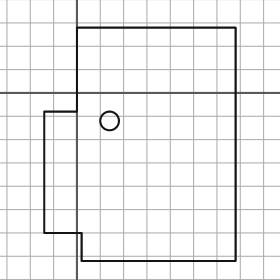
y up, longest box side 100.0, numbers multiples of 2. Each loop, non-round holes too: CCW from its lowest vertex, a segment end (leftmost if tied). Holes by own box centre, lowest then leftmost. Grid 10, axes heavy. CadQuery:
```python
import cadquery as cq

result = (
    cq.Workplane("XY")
    .moveTo(2.0, -72.0)
    .lineTo(68.0, -72.0)
    .lineTo(68.0, 28.0)
    .lineTo(0.0, 28.0)
    .lineTo(0.0, -8.0)
    .lineTo(-14.0, -8.0)
    .lineTo(-14.0, -60.0)
    .lineTo(2.0, -60.0)
    .close()
    .moveTo(14.0, -12.0)
    .circle(4.0)
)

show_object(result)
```